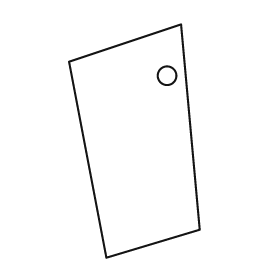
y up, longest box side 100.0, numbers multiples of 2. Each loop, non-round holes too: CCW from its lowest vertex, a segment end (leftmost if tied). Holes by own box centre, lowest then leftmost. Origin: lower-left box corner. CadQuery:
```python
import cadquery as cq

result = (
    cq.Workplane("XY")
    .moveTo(16.0, 0.0)
    .lineTo(56.0, 12.0)
    .lineTo(48.0, 100.0)
    .lineTo(0.0, 84.0)
    .close()
    .moveTo(42.0, 78.0)
    .circle(4.0)
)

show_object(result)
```